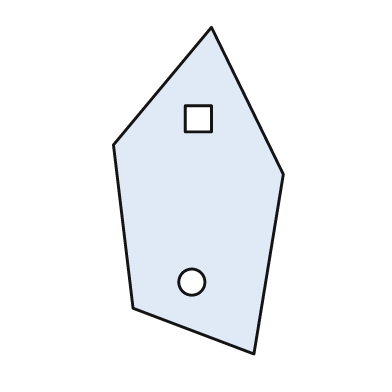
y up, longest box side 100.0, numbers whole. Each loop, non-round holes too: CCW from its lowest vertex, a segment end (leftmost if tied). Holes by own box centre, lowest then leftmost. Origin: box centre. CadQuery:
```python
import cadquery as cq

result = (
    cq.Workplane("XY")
    .moveTo(17.0, -50.0)
    .lineTo(26.0, 5.0)
    .lineTo(4.0, 50.0)
    .lineTo(-26.0, 14.0)
    .lineTo(-20.0, -36.0)
    .close()
    .moveTo(-2.0, -28.0)
    .circle(4.0)
    .moveTo(-4.0, 18.0)
    .lineTo(4.0, 18.0)
    .lineTo(4.0, 26.0)
    .lineTo(-4.0, 26.0)
    .close()
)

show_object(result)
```